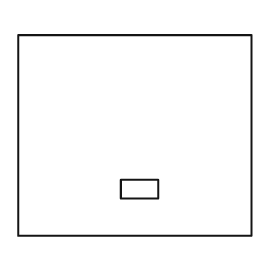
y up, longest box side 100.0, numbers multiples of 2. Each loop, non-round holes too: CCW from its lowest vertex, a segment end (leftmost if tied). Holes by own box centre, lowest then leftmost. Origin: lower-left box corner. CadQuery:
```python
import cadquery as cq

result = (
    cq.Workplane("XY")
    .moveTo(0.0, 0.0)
    .lineTo(100.0, 0.0)
    .lineTo(100.0, 86.0)
    .lineTo(0.0, 86.0)
    .close()
    .moveTo(44.0, 16.0)
    .lineTo(60.0, 16.0)
    .lineTo(60.0, 24.0)
    .lineTo(44.0, 24.0)
    .close()
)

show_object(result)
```